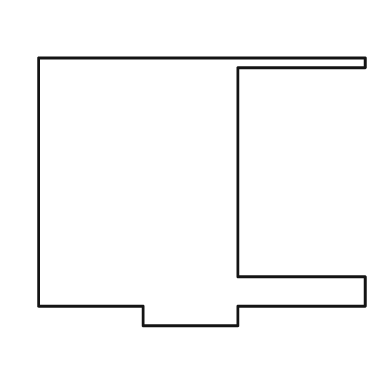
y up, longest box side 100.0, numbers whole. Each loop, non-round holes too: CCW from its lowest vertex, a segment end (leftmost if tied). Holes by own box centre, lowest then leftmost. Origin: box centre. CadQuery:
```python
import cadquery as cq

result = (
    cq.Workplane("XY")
    .moveTo(-18.0, -41.0)
    .lineTo(11.0, -41.0)
    .lineTo(11.0, -35.0)
    .lineTo(50.0, -35.0)
    .lineTo(50.0, -26.0)
    .lineTo(11.0, -26.0)
    .lineTo(11.0, 38.0)
    .lineTo(50.0, 38.0)
    .lineTo(50.0, 41.0)
    .lineTo(-50.0, 41.0)
    .lineTo(-50.0, -35.0)
    .lineTo(-18.0, -35.0)
    .close()
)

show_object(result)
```